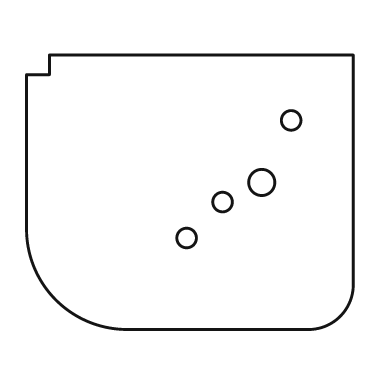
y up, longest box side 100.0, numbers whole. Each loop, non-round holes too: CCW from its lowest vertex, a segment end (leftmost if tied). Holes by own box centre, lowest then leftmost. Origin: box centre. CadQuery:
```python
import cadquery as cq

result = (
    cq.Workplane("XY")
    .moveTo(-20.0, -42.0)
    .lineTo(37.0, -42.0)
    .threePointArc((46.0, -38.0), (50.0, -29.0))
    .lineTo(50.0, 42.0)
    .lineTo(-43.0, 42.0)
    .lineTo(-43.0, 36.0)
    .lineTo(-50.0, 36.0)
    .lineTo(-50.0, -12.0)
    .threePointArc((-41.0, -33.0), (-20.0, -42.0))
    .close()
    .moveTo(-1.0, -14.0)
    .circle(3.0)
    .moveTo(10.0, -3.0)
    .circle(3.0)
    .moveTo(22.0, 3.0)
    .circle(4.0)
    .moveTo(31.0, 22.0)
    .circle(3.0)
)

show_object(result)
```